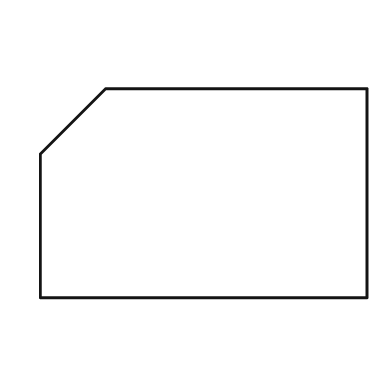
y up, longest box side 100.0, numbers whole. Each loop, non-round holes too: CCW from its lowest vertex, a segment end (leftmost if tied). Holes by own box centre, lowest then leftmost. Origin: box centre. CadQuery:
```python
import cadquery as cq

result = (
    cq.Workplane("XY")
    .moveTo(-50.0, -32.0)
    .lineTo(50.0, -32.0)
    .lineTo(50.0, 32.0)
    .lineTo(-30.0, 32.0)
    .lineTo(-50.0, 12.0)
    .close()
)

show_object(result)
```